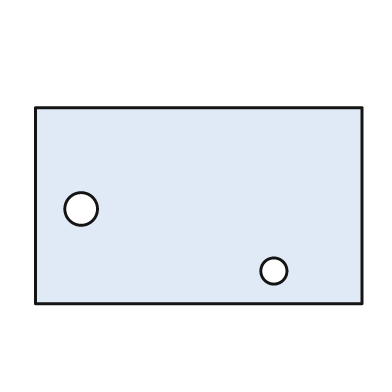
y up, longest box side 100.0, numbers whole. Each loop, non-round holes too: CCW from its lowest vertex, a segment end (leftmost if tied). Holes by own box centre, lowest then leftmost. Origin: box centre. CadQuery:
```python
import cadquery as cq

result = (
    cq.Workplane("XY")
    .moveTo(-50.0, -30.0)
    .lineTo(50.0, -30.0)
    .lineTo(50.0, 30.0)
    .lineTo(-50.0, 30.0)
    .close()
    .moveTo(23.0, -20.0)
    .circle(4.0)
    .moveTo(-36.0, -1.0)
    .circle(5.0)
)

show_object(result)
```